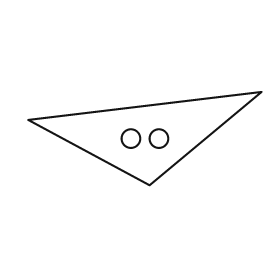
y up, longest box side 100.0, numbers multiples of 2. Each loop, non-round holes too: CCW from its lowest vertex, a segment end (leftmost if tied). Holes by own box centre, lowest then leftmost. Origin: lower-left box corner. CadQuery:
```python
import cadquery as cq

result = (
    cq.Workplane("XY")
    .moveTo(52.0, 0.0)
    .lineTo(100.0, 40.0)
    .lineTo(0.0, 28.0)
    .close()
    .moveTo(44.0, 20.0)
    .circle(4.0)
    .moveTo(56.0, 20.0)
    .circle(4.0)
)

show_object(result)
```